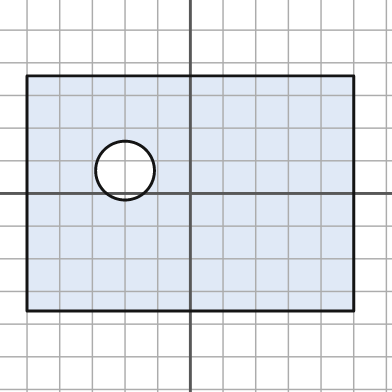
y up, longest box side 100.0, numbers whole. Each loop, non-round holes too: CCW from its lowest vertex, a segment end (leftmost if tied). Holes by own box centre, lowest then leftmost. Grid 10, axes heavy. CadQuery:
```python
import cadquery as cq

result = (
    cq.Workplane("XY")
    .moveTo(-50.0, -36.0)
    .lineTo(50.0, -36.0)
    .lineTo(50.0, 36.0)
    .lineTo(-50.0, 36.0)
    .close()
    .moveTo(-20.0, 7.0)
    .circle(9.0)
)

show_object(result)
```